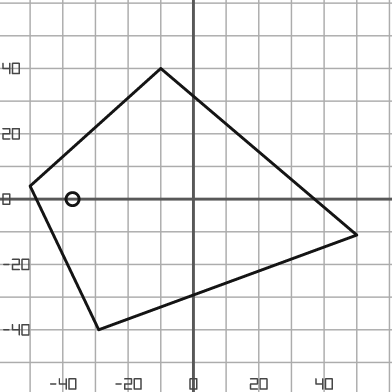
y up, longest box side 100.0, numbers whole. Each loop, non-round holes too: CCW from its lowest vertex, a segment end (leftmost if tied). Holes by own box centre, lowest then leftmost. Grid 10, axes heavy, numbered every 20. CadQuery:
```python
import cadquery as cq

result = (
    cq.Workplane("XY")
    .moveTo(-29.0, -40.0)
    .lineTo(50.0, -11.0)
    .lineTo(-10.0, 40.0)
    .lineTo(-50.0, 4.0)
    .close()
    .moveTo(-37.0, 0.0)
    .circle(2.0)
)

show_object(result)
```